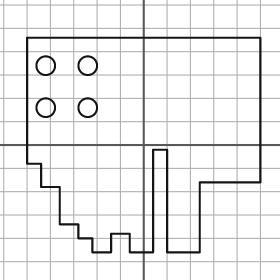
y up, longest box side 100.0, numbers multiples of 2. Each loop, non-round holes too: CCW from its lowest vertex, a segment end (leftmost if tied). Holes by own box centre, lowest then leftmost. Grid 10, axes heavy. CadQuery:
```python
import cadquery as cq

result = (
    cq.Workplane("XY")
    .moveTo(-22.0, -46.0)
    .lineTo(-14.0, -46.0)
    .lineTo(-14.0, -38.0)
    .lineTo(-6.0, -38.0)
    .lineTo(-6.0, -46.0)
    .lineTo(4.0, -46.0)
    .lineTo(4.0, -2.0)
    .lineTo(10.0, -2.0)
    .lineTo(10.0, -46.0)
    .lineTo(24.0, -46.0)
    .lineTo(24.0, -16.0)
    .lineTo(50.0, -16.0)
    .lineTo(50.0, 46.0)
    .lineTo(-50.0, 46.0)
    .lineTo(-50.0, -8.0)
    .lineTo(-44.0, -8.0)
    .lineTo(-44.0, -18.0)
    .lineTo(-36.0, -18.0)
    .lineTo(-36.0, -34.0)
    .lineTo(-28.0, -34.0)
    .lineTo(-28.0, -40.0)
    .lineTo(-22.0, -40.0)
    .close()
    .moveTo(-42.0, 16.0)
    .circle(4.0)
    .moveTo(-24.0, 16.0)
    .circle(4.0)
    .moveTo(-42.0, 34.0)
    .circle(4.0)
    .moveTo(-24.0, 34.0)
    .circle(4.0)
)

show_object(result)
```